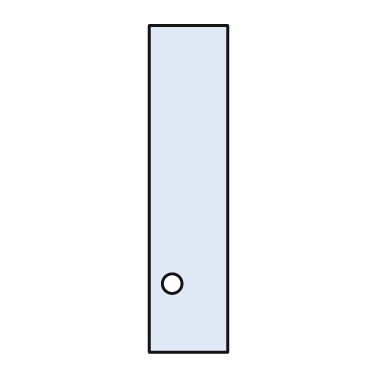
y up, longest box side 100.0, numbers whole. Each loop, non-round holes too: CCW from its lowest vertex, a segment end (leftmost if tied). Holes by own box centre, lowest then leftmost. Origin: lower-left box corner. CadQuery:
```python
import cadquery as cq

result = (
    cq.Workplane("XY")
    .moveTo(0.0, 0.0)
    .lineTo(24.0, 0.0)
    .lineTo(24.0, 100.0)
    .lineTo(0.0, 100.0)
    .close()
    .moveTo(7.0, 21.0)
    .circle(3.0)
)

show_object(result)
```